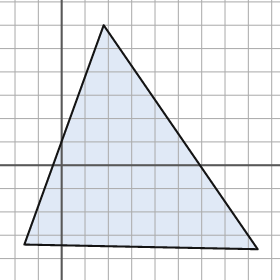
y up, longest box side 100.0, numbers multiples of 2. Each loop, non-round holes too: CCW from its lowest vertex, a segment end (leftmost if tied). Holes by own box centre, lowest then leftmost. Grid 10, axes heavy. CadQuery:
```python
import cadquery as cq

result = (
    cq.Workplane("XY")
    .moveTo(84.0, -36.0)
    .lineTo(18.0, 60.0)
    .lineTo(-16.0, -34.0)
    .close()
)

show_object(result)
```